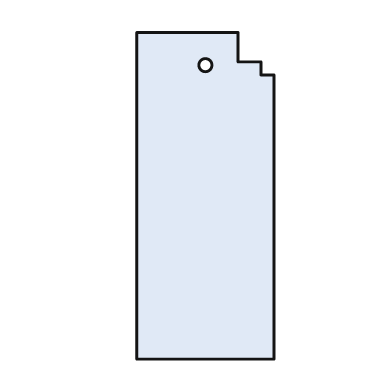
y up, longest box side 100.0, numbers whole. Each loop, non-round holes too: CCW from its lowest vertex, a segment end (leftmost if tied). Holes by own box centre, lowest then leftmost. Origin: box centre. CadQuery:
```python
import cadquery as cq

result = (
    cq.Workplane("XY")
    .moveTo(-21.0, -50.0)
    .lineTo(21.0, -50.0)
    .lineTo(21.0, 37.0)
    .lineTo(17.0, 37.0)
    .lineTo(17.0, 41.0)
    .lineTo(10.0, 41.0)
    .lineTo(10.0, 50.0)
    .lineTo(-21.0, 50.0)
    .close()
    .moveTo(0.0, 40.0)
    .circle(2.0)
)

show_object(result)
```